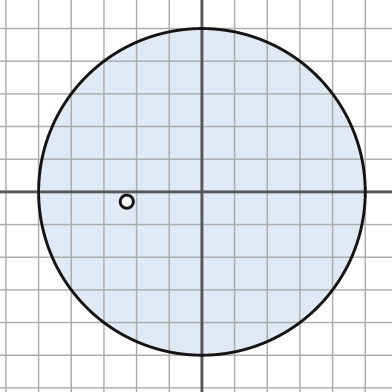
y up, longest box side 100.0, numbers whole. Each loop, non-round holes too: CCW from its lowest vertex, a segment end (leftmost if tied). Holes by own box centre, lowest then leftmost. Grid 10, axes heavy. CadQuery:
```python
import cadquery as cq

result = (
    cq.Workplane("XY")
    .moveTo(0.0, 0.0)
    .circle(50.0)
    .moveTo(-23.0, -3.0)
    .circle(2.0)
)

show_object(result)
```